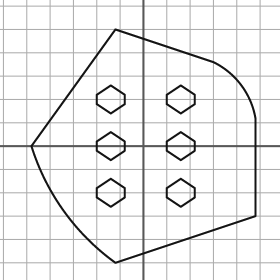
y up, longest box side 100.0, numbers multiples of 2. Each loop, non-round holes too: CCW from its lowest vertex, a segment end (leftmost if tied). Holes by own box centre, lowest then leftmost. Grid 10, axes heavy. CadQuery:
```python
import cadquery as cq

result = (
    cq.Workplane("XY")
    .moveTo(-12.0, -50.0)
    .lineTo(48.0, -30.0)
    .lineTo(48.0, 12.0)
    .threePointArc((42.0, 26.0), (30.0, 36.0))
    .lineTo(-12.0, 50.0)
    .lineTo(-48.0, 0.0)
    .threePointArc((-34.0, -28.0), (-12.0, -50.0))
    .close()
    .moveTo(-14.0, -26.0)
    .lineTo(-8.0, -22.0)
    .lineTo(-8.0, -18.0)
    .lineTo(-14.0, -14.0)
    .lineTo(-20.0, -18.0)
    .lineTo(-20.0, -22.0)
    .close()
    .moveTo(16.0, -26.0)
    .lineTo(22.0, -22.0)
    .lineTo(22.0, -18.0)
    .lineTo(16.0, -14.0)
    .lineTo(10.0, -18.0)
    .lineTo(10.0, -22.0)
    .close()
    .moveTo(-14.0, -6.0)
    .lineTo(-8.0, -2.0)
    .lineTo(-8.0, 2.0)
    .lineTo(-14.0, 6.0)
    .lineTo(-20.0, 2.0)
    .lineTo(-20.0, -2.0)
    .close()
    .moveTo(16.0, -6.0)
    .lineTo(22.0, -2.0)
    .lineTo(22.0, 2.0)
    .lineTo(16.0, 6.0)
    .lineTo(10.0, 2.0)
    .lineTo(10.0, -2.0)
    .close()
    .moveTo(-14.0, 14.0)
    .lineTo(-8.0, 18.0)
    .lineTo(-8.0, 22.0)
    .lineTo(-14.0, 26.0)
    .lineTo(-20.0, 22.0)
    .lineTo(-20.0, 18.0)
    .close()
    .moveTo(16.0, 14.0)
    .lineTo(22.0, 18.0)
    .lineTo(22.0, 22.0)
    .lineTo(16.0, 26.0)
    .lineTo(10.0, 22.0)
    .lineTo(10.0, 18.0)
    .close()
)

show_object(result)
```